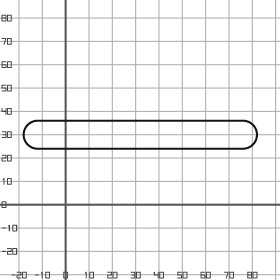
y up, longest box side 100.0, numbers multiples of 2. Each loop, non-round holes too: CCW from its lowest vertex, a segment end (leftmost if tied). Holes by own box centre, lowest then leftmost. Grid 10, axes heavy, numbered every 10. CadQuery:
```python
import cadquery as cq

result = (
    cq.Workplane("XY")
    .moveTo(-12.0, 24.0)
    .lineTo(76.0, 24.0)
    .threePointArc((82.0, 30.0), (76.0, 36.0))
    .lineTo(-12.0, 36.0)
    .threePointArc((-18.0, 30.0), (-12.0, 24.0))
    .close()
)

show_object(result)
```